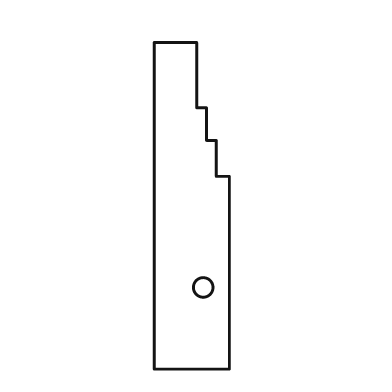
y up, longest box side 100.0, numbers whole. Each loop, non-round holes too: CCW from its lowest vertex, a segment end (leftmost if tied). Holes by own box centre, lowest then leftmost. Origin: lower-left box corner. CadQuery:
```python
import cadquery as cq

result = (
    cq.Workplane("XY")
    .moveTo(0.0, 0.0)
    .lineTo(23.0, 0.0)
    .lineTo(23.0, 59.0)
    .lineTo(19.0, 59.0)
    .lineTo(19.0, 70.0)
    .lineTo(16.0, 70.0)
    .lineTo(16.0, 80.0)
    .lineTo(13.0, 80.0)
    .lineTo(13.0, 100.0)
    .lineTo(0.0, 100.0)
    .close()
    .moveTo(15.0, 25.0)
    .circle(3.0)
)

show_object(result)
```